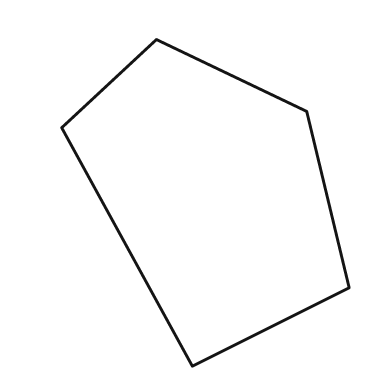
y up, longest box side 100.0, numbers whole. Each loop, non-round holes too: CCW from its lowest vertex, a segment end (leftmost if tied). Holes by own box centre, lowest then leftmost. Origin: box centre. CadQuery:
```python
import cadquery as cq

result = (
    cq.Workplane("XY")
    .moveTo(-4.0, -50.0)
    .lineTo(44.0, -26.0)
    .lineTo(31.0, 28.0)
    .lineTo(-15.0, 50.0)
    .lineTo(-44.0, 23.0)
    .close()
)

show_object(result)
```